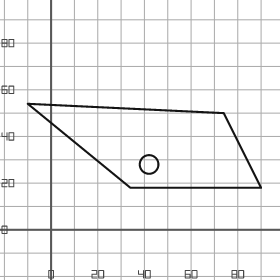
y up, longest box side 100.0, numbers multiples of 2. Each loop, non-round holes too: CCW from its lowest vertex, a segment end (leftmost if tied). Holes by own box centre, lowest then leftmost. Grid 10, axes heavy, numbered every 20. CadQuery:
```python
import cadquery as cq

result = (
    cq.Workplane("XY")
    .moveTo(34.0, 18.0)
    .lineTo(90.0, 18.0)
    .lineTo(74.0, 50.0)
    .lineTo(-10.0, 54.0)
    .close()
    .moveTo(42.0, 28.0)
    .circle(4.0)
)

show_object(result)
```